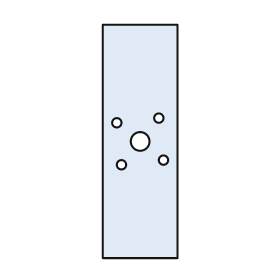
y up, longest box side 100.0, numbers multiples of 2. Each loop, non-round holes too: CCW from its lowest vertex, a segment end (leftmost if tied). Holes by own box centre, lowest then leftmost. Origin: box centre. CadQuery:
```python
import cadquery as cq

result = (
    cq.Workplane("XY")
    .moveTo(-16.0, -50.0)
    .lineTo(16.0, -50.0)
    .lineTo(16.0, 50.0)
    .lineTo(-16.0, 50.0)
    .close()
    .moveTo(-8.0, -10.0)
    .circle(2.0)
    .moveTo(10.0, -8.0)
    .circle(2.0)
    .moveTo(0.0, 0.0)
    .circle(4.0)
    .moveTo(-10.0, 8.0)
    .circle(2.0)
    .moveTo(8.0, 10.0)
    .circle(2.0)
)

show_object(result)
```